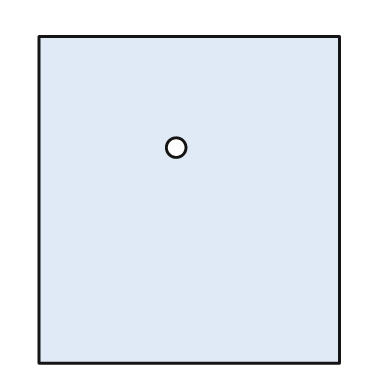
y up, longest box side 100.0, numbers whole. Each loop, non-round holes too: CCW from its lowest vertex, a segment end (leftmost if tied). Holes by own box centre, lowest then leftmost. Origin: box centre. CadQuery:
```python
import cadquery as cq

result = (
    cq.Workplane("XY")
    .moveTo(-46.0, -50.0)
    .lineTo(46.0, -50.0)
    .lineTo(46.0, 50.0)
    .lineTo(-46.0, 50.0)
    .close()
    .moveTo(-4.0, 16.0)
    .circle(3.0)
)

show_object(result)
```